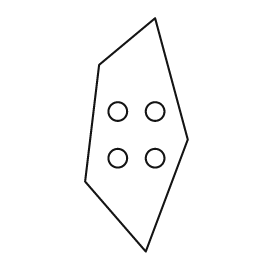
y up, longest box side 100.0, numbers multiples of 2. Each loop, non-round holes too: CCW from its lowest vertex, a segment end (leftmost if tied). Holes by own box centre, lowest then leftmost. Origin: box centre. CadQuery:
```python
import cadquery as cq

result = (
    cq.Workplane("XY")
    .moveTo(4.0, -50.0)
    .lineTo(22.0, -2.0)
    .lineTo(8.0, 50.0)
    .lineTo(-16.0, 30.0)
    .lineTo(-22.0, -20.0)
    .close()
    .moveTo(-8.0, -10.0)
    .circle(4.0)
    .moveTo(8.0, -10.0)
    .circle(4.0)
    .moveTo(-8.0, 10.0)
    .circle(4.0)
    .moveTo(8.0, 10.0)
    .circle(4.0)
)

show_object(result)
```